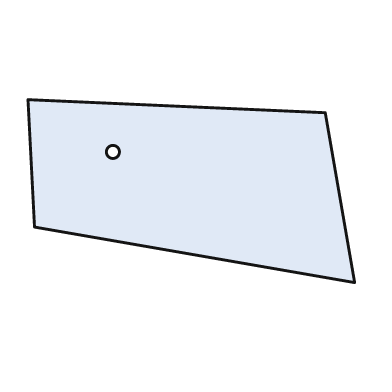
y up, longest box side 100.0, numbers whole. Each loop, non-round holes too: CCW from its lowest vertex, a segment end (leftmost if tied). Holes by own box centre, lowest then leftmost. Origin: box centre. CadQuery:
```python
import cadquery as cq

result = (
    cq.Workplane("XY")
    .moveTo(50.0, -28.0)
    .lineTo(41.0, 24.0)
    .lineTo(-50.0, 28.0)
    .lineTo(-48.0, -11.0)
    .close()
    .moveTo(-24.0, 12.0)
    .circle(2.0)
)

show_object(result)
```